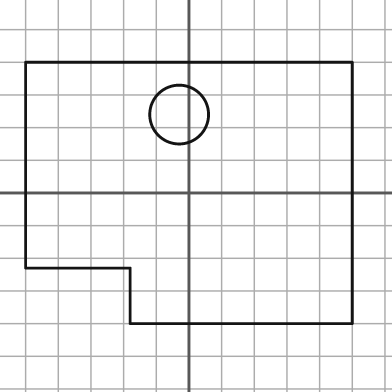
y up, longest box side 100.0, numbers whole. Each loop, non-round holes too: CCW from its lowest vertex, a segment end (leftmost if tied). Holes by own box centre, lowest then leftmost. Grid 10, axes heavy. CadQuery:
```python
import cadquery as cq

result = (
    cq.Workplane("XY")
    .moveTo(-18.0, -40.0)
    .lineTo(50.0, -40.0)
    .lineTo(50.0, 40.0)
    .lineTo(-50.0, 40.0)
    .lineTo(-50.0, -23.0)
    .lineTo(-18.0, -23.0)
    .close()
    .moveTo(-3.0, 24.0)
    .circle(9.0)
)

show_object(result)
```